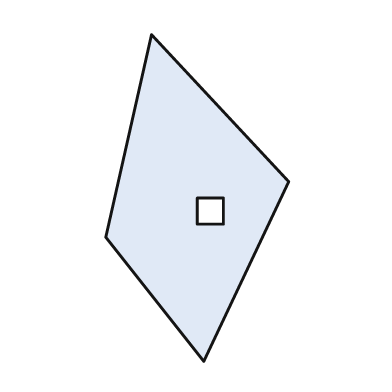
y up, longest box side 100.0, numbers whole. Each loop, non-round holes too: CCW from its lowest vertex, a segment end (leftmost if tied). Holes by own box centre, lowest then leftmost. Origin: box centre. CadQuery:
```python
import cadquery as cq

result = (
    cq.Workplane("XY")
    .moveTo(2.0, -50.0)
    .lineTo(28.0, 5.0)
    .lineTo(-14.0, 50.0)
    .lineTo(-28.0, -12.0)
    .close()
    .moveTo(0.0, -8.0)
    .lineTo(8.0, -8.0)
    .lineTo(8.0, 0.0)
    .lineTo(0.0, 0.0)
    .close()
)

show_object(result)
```